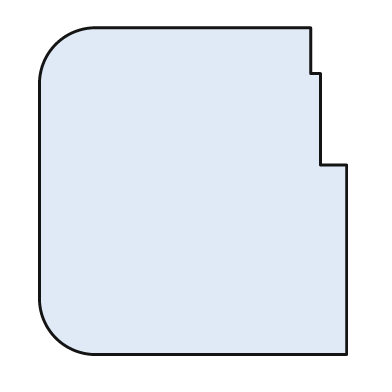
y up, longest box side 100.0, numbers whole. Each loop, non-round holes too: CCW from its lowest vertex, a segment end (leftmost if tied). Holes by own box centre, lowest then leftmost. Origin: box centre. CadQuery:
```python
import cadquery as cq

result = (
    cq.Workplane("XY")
    .moveTo(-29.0, -50.0)
    .lineTo(47.0, -50.0)
    .lineTo(47.0, 8.0)
    .lineTo(39.0, 8.0)
    .lineTo(39.0, 36.0)
    .lineTo(36.0, 36.0)
    .lineTo(36.0, 50.0)
    .lineTo(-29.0, 50.0)
    .threePointArc((-42.0, 45.0), (-47.0, 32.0))
    .lineTo(-47.0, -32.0)
    .threePointArc((-42.0, -45.0), (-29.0, -50.0))
    .close()
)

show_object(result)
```